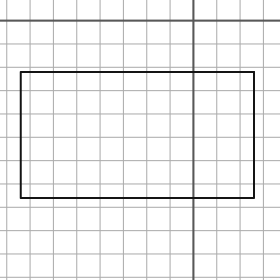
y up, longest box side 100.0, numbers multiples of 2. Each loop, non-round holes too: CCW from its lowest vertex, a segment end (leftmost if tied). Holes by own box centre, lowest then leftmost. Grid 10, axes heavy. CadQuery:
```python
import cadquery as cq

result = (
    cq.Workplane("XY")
    .moveTo(-74.0, -76.0)
    .lineTo(26.0, -76.0)
    .lineTo(26.0, -22.0)
    .lineTo(-74.0, -22.0)
    .close()
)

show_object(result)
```